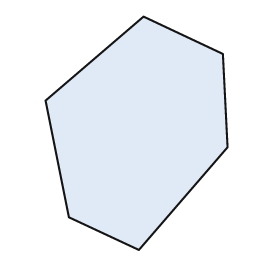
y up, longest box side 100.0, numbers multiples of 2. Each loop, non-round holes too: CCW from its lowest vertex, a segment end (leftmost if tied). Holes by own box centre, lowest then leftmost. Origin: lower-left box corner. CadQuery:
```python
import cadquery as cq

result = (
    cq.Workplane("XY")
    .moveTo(40.0, 0.0)
    .lineTo(78.0, 44.0)
    .lineTo(76.0, 84.0)
    .lineTo(42.0, 100.0)
    .lineTo(0.0, 64.0)
    .lineTo(10.0, 14.0)
    .close()
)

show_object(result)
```